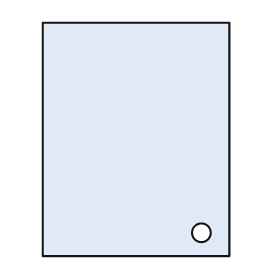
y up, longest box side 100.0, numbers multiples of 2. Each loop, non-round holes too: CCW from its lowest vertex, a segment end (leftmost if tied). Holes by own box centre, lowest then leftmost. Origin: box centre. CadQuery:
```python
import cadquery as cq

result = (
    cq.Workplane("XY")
    .moveTo(-40.0, -50.0)
    .lineTo(40.0, -50.0)
    .lineTo(40.0, 50.0)
    .lineTo(-40.0, 50.0)
    .close()
    .moveTo(28.0, -40.0)
    .circle(4.0)
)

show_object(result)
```